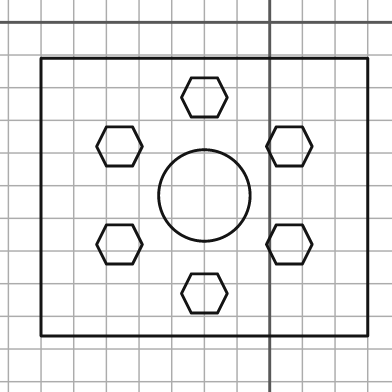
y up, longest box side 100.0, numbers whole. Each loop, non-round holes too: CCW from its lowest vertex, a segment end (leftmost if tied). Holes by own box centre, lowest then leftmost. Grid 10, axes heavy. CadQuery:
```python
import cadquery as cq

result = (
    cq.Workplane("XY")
    .moveTo(-70.0, -96.0)
    .lineTo(30.0, -96.0)
    .lineTo(30.0, -11.0)
    .lineTo(-70.0, -11.0)
    .close()
    .moveTo(-24.0, -89.0)
    .lineTo(-16.0, -89.0)
    .lineTo(-13.0, -83.0)
    .lineTo(-16.0, -77.0)
    .lineTo(-24.0, -77.0)
    .lineTo(-27.0, -83.0)
    .close()
    .moveTo(-50.0, -74.0)
    .lineTo(-42.0, -74.0)
    .lineTo(-39.0, -68.0)
    .lineTo(-42.0, -62.0)
    .lineTo(-50.0, -62.0)
    .lineTo(-53.0, -68.0)
    .close()
    .moveTo(2.0, -74.0)
    .lineTo(10.0, -74.0)
    .lineTo(13.0, -68.0)
    .lineTo(10.0, -62.0)
    .lineTo(2.0, -62.0)
    .lineTo(-1.0, -68.0)
    .close()
    .moveTo(-20.0, -53.0)
    .circle(14.0)
    .moveTo(-50.0, -44.0)
    .lineTo(-42.0, -44.0)
    .lineTo(-39.0, -38.0)
    .lineTo(-42.0, -32.0)
    .lineTo(-50.0, -32.0)
    .lineTo(-53.0, -38.0)
    .close()
    .moveTo(2.0, -44.0)
    .lineTo(10.0, -44.0)
    .lineTo(13.0, -38.0)
    .lineTo(10.0, -32.0)
    .lineTo(2.0, -32.0)
    .lineTo(-1.0, -38.0)
    .close()
    .moveTo(-24.0, -29.0)
    .lineTo(-16.0, -29.0)
    .lineTo(-13.0, -23.0)
    .lineTo(-16.0, -17.0)
    .lineTo(-24.0, -17.0)
    .lineTo(-27.0, -23.0)
    .close()
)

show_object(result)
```